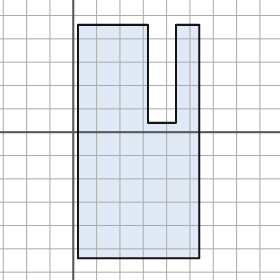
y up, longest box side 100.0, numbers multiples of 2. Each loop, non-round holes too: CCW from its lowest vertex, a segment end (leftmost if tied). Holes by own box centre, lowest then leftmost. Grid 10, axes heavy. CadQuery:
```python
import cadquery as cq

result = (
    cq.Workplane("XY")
    .moveTo(2.0, -54.0)
    .lineTo(54.0, -54.0)
    .lineTo(54.0, 46.0)
    .lineTo(44.0, 46.0)
    .lineTo(44.0, 4.0)
    .lineTo(32.0, 4.0)
    .lineTo(32.0, 46.0)
    .lineTo(2.0, 46.0)
    .close()
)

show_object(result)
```